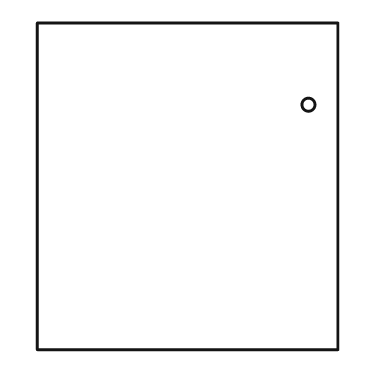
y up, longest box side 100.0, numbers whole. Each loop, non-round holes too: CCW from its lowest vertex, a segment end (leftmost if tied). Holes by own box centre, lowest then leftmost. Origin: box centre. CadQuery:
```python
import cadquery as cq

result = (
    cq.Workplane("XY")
    .moveTo(-46.0, -50.0)
    .lineTo(46.0, -50.0)
    .lineTo(46.0, 50.0)
    .lineTo(-46.0, 50.0)
    .close()
    .moveTo(37.0, 25.0)
    .circle(2.0)
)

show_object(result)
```